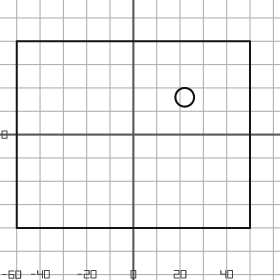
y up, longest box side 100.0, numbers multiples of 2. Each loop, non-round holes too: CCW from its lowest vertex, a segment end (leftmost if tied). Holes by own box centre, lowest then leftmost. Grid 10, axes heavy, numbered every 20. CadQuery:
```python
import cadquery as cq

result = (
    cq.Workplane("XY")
    .moveTo(-50.0, -40.0)
    .lineTo(50.0, -40.0)
    .lineTo(50.0, 40.0)
    .lineTo(-50.0, 40.0)
    .close()
    .moveTo(22.0, 16.0)
    .circle(4.0)
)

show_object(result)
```